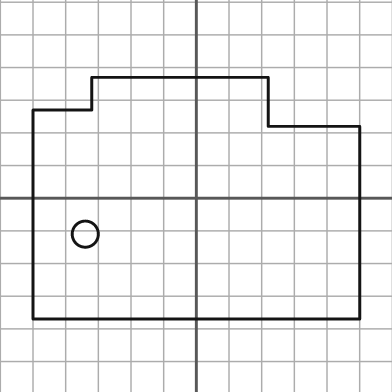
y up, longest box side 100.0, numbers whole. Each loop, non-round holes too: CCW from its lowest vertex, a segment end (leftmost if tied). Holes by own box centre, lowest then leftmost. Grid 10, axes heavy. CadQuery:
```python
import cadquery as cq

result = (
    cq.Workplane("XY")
    .moveTo(-50.0, -37.0)
    .lineTo(50.0, -37.0)
    .lineTo(50.0, 22.0)
    .lineTo(22.0, 22.0)
    .lineTo(22.0, 37.0)
    .lineTo(-32.0, 37.0)
    .lineTo(-32.0, 27.0)
    .lineTo(-50.0, 27.0)
    .close()
    .moveTo(-34.0, -11.0)
    .circle(4.0)
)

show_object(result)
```